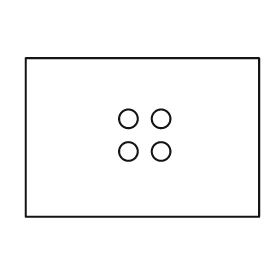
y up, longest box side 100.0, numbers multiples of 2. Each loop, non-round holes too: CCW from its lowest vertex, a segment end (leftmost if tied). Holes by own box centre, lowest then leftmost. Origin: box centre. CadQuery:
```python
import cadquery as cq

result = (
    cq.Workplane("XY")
    .moveTo(-50.0, -34.0)
    .lineTo(50.0, -34.0)
    .lineTo(50.0, 34.0)
    .lineTo(-50.0, 34.0)
    .close()
    .moveTo(-6.0, -6.0)
    .circle(4.0)
    .moveTo(8.0, -6.0)
    .circle(4.0)
    .moveTo(-6.0, 8.0)
    .circle(4.0)
    .moveTo(8.0, 8.0)
    .circle(4.0)
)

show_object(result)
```